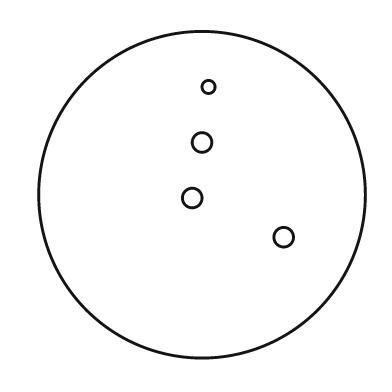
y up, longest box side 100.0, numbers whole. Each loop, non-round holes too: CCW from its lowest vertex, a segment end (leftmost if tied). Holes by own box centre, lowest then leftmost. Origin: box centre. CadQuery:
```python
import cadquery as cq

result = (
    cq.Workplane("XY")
    .moveTo(0.0, 0.0)
    .circle(50.0)
    .moveTo(25.0, -13.0)
    .circle(3.0)
    .moveTo(-3.0, -1.0)
    .circle(3.0)
    .moveTo(0.0, 16.0)
    .circle(3.0)
    .moveTo(2.0, 33.0)
    .circle(2.0)
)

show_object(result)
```